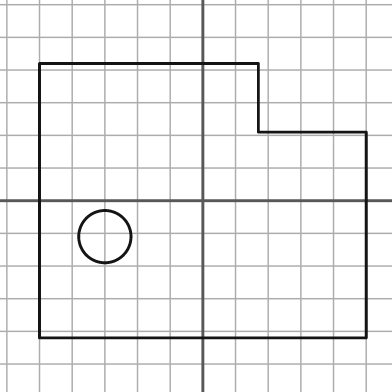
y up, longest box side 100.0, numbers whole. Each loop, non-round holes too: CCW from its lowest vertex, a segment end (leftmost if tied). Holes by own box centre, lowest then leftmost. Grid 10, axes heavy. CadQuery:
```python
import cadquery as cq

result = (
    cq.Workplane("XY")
    .moveTo(-50.0, -42.0)
    .lineTo(50.0, -42.0)
    .lineTo(50.0, 21.0)
    .lineTo(17.0, 21.0)
    .lineTo(17.0, 42.0)
    .lineTo(-50.0, 42.0)
    .close()
    .moveTo(-30.0, -11.0)
    .circle(8.0)
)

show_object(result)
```